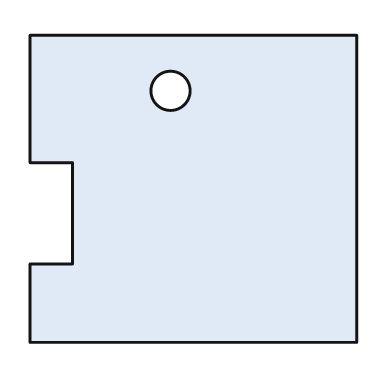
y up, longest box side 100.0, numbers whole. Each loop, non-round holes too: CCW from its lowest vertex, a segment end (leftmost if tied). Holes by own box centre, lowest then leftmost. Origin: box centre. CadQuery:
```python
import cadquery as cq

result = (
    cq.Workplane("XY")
    .moveTo(-50.0, -47.0)
    .lineTo(50.0, -47.0)
    .lineTo(50.0, 47.0)
    .lineTo(-50.0, 47.0)
    .lineTo(-50.0, 8.0)
    .lineTo(-37.0, 8.0)
    .lineTo(-37.0, -23.0)
    .lineTo(-50.0, -23.0)
    .close()
    .moveTo(-7.0, 30.0)
    .circle(6.0)
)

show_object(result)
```